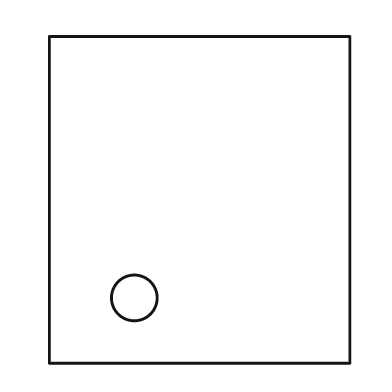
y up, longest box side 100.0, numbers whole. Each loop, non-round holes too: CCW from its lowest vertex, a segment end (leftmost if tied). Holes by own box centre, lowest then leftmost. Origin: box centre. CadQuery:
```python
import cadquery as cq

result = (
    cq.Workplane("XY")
    .moveTo(-46.0, -50.0)
    .lineTo(46.0, -50.0)
    .lineTo(46.0, 50.0)
    .lineTo(-46.0, 50.0)
    .close()
    .moveTo(-20.0, -30.0)
    .circle(7.0)
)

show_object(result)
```